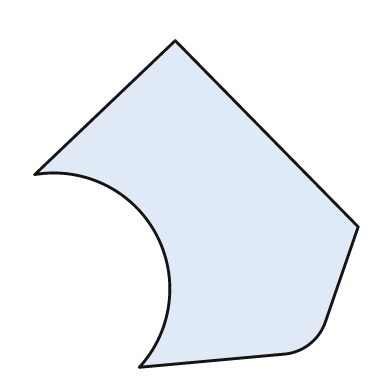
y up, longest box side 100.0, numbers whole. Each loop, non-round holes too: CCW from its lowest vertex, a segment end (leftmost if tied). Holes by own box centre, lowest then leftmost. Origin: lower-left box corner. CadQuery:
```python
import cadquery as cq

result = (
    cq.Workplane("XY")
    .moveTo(32.0, 0.0)
    .lineTo(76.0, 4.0)
    .threePointArc((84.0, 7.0), (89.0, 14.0))
    .lineTo(99.0, 43.0)
    .lineTo(43.0, 100.0)
    .lineTo(0.0, 59.0)
    .threePointArc((37.0, 41.0), (32.0, 0.0))
    .close()
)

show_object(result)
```